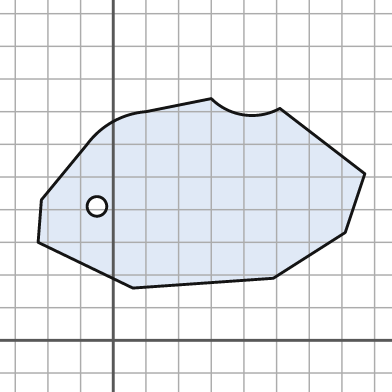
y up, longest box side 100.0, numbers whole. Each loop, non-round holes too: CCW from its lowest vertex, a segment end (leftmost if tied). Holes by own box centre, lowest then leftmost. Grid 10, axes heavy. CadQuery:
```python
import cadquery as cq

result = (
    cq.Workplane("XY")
    .moveTo(6.0, 16.0)
    .lineTo(49.0, 19.0)
    .lineTo(71.0, 33.0)
    .lineTo(77.0, 51.0)
    .lineTo(51.0, 71.0)
    .threePointArc((40.0, 69.0), (30.0, 74.0))
    .lineTo(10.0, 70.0)
    .threePointArc((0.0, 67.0), (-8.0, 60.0))
    .lineTo(-22.0, 43.0)
    .lineTo(-23.0, 30.0)
    .close()
    .moveTo(-5.0, 41.0)
    .circle(3.0)
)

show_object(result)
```